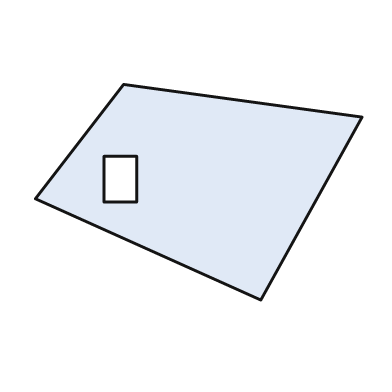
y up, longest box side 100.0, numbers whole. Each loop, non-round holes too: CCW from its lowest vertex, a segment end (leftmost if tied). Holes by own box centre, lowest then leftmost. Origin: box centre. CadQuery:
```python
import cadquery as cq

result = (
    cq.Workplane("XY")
    .moveTo(19.0, -33.0)
    .lineTo(50.0, 23.0)
    .lineTo(-23.0, 33.0)
    .lineTo(-50.0, -2.0)
    .close()
    .moveTo(-29.0, -3.0)
    .lineTo(-19.0, -3.0)
    .lineTo(-19.0, 11.0)
    .lineTo(-29.0, 11.0)
    .close()
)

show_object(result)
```